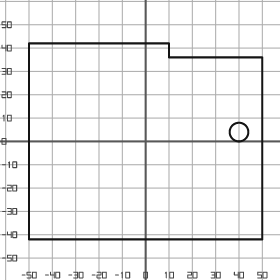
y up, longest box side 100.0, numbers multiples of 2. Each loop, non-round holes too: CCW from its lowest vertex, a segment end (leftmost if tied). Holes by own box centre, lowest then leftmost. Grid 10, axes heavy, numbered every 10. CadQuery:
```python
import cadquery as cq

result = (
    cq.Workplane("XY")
    .moveTo(-50.0, -42.0)
    .lineTo(50.0, -42.0)
    .lineTo(50.0, 36.0)
    .lineTo(10.0, 36.0)
    .lineTo(10.0, 42.0)
    .lineTo(-50.0, 42.0)
    .close()
    .moveTo(40.0, 4.0)
    .circle(4.0)
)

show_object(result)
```